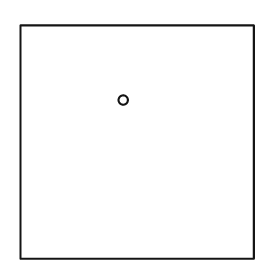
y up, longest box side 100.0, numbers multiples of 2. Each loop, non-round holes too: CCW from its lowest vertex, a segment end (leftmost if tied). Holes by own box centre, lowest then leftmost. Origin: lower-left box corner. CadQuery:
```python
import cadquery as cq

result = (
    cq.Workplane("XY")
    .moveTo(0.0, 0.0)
    .lineTo(100.0, 0.0)
    .lineTo(100.0, 100.0)
    .lineTo(0.0, 100.0)
    .close()
    .moveTo(44.0, 68.0)
    .circle(2.0)
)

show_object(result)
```